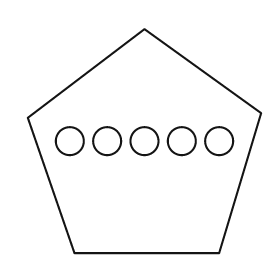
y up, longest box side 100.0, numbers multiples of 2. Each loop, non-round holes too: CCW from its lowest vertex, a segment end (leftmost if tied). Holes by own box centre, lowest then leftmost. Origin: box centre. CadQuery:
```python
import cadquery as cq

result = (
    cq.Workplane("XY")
    .moveTo(-30.0, -48.0)
    .lineTo(32.0, -48.0)
    .lineTo(50.0, 12.0)
    .lineTo(0.0, 48.0)
    .lineTo(-50.0, 10.0)
    .close()
    .moveTo(-32.0, 0.0)
    .circle(6.0)
    .moveTo(-16.0, 0.0)
    .circle(6.0)
    .moveTo(0.0, 0.0)
    .circle(6.0)
    .moveTo(16.0, 0.0)
    .circle(6.0)
    .moveTo(32.0, 0.0)
    .circle(6.0)
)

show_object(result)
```